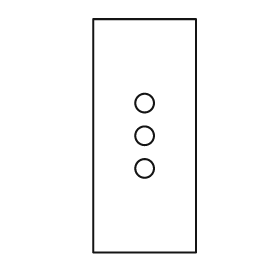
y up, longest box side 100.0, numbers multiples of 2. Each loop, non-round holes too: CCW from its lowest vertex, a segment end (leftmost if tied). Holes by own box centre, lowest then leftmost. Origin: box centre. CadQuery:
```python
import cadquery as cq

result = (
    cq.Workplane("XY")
    .moveTo(-22.0, -50.0)
    .lineTo(22.0, -50.0)
    .lineTo(22.0, 50.0)
    .lineTo(-22.0, 50.0)
    .close()
    .moveTo(0.0, -14.0)
    .circle(4.0)
    .moveTo(0.0, 0.0)
    .circle(4.0)
    .moveTo(0.0, 14.0)
    .circle(4.0)
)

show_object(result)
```